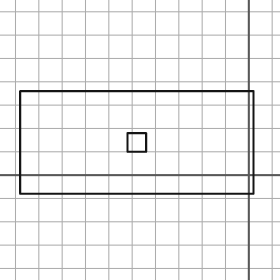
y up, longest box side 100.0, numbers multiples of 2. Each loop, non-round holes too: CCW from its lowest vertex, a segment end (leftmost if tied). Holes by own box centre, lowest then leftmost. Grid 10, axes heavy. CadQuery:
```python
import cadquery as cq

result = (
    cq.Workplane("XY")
    .moveTo(-98.0, -8.0)
    .lineTo(2.0, -8.0)
    .lineTo(2.0, 36.0)
    .lineTo(-98.0, 36.0)
    .close()
    .moveTo(-52.0, 10.0)
    .lineTo(-44.0, 10.0)
    .lineTo(-44.0, 18.0)
    .lineTo(-52.0, 18.0)
    .close()
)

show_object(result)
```